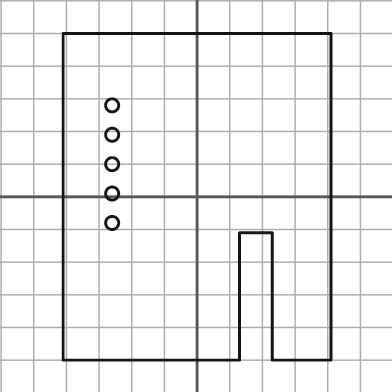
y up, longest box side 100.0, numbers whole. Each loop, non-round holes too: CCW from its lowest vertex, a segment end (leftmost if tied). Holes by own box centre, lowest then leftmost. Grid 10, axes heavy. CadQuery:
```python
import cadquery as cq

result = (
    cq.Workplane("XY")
    .moveTo(-41.0, -50.0)
    .lineTo(13.0, -50.0)
    .lineTo(13.0, -11.0)
    .lineTo(23.0, -11.0)
    .lineTo(23.0, -50.0)
    .lineTo(41.0, -50.0)
    .lineTo(41.0, 50.0)
    .lineTo(-41.0, 50.0)
    .close()
    .moveTo(-26.0, -8.0)
    .circle(2.0)
    .moveTo(-26.0, 1.0)
    .circle(2.0)
    .moveTo(-26.0, 10.0)
    .circle(2.0)
    .moveTo(-26.0, 19.0)
    .circle(2.0)
    .moveTo(-26.0, 28.0)
    .circle(2.0)
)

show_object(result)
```